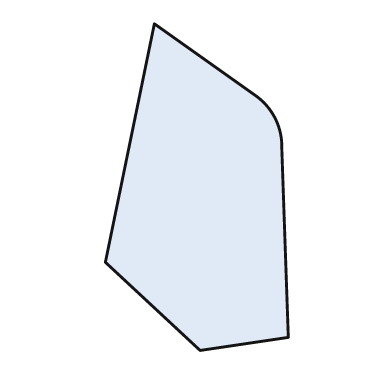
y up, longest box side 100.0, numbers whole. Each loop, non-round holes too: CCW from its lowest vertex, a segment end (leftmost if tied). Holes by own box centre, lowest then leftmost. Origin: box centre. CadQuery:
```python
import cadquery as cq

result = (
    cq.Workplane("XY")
    .moveTo(1.0, -50.0)
    .lineTo(28.0, -46.0)
    .lineTo(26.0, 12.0)
    .threePointArc((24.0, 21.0), (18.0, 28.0))
    .lineTo(-13.0, 50.0)
    .lineTo(-28.0, -23.0)
    .close()
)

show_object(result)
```